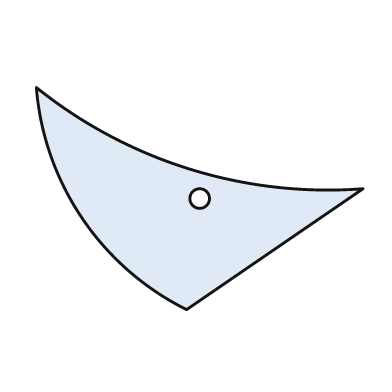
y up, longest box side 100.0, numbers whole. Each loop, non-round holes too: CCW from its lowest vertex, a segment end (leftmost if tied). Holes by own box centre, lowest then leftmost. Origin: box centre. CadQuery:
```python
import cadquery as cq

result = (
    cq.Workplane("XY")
    .moveTo(-4.0, -34.0)
    .lineTo(50.0, 3.0)
    .threePointArc((-3.0, 9.0), (-50.0, 34.0))
    .threePointArc((-36.0, -6.0), (-4.0, -34.0))
    .close()
    .moveTo(0.0, 0.0)
    .circle(3.0)
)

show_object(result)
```